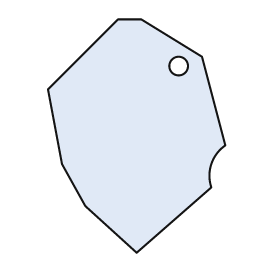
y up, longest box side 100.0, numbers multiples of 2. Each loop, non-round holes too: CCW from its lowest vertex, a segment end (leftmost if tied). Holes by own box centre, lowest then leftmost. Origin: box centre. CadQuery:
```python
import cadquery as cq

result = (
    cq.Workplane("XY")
    .moveTo(0.0, -50.0)
    .lineTo(32.0, -22.0)
    .threePointArc((32.0, -12.0), (38.0, -4.0))
    .lineTo(28.0, 34.0)
    .lineTo(2.0, 50.0)
    .lineTo(-8.0, 50.0)
    .lineTo(-38.0, 20.0)
    .lineTo(-32.0, -12.0)
    .lineTo(-22.0, -30.0)
    .close()
    .moveTo(18.0, 30.0)
    .circle(4.0)
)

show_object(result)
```